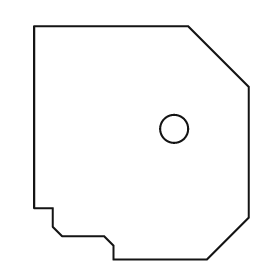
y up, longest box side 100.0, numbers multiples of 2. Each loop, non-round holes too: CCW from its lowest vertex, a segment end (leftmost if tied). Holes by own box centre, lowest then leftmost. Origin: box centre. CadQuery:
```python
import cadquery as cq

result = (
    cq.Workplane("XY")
    .moveTo(-12.0, -50.0)
    .lineTo(28.0, -50.0)
    .lineTo(46.0, -32.0)
    .lineTo(46.0, 24.0)
    .lineTo(20.0, 50.0)
    .lineTo(-46.0, 50.0)
    .lineTo(-46.0, -28.0)
    .lineTo(-38.0, -28.0)
    .lineTo(-38.0, -36.0)
    .lineTo(-34.0, -40.0)
    .lineTo(-16.0, -40.0)
    .lineTo(-12.0, -44.0)
    .close()
    .moveTo(14.0, 6.0)
    .circle(6.0)
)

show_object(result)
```